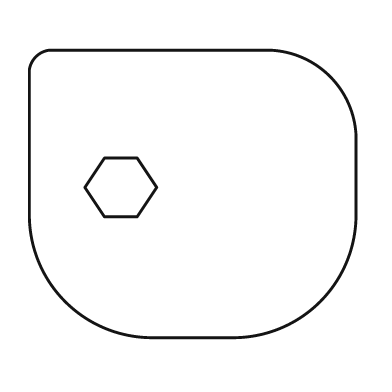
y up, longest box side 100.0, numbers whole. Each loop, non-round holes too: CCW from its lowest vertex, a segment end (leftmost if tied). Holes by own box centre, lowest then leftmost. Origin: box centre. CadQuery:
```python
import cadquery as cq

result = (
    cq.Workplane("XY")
    .moveTo(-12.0, -44.0)
    .lineTo(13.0, -44.0)
    .threePointArc((39.0, -33.0), (50.0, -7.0))
    .lineTo(50.0, 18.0)
    .threePointArc((42.0, 36.0), (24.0, 44.0))
    .lineTo(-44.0, 44.0)
    .threePointArc((-48.0, 42.0), (-50.0, 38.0))
    .lineTo(-50.0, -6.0)
    .threePointArc((-39.0, -33.0), (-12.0, -44.0))
    .close()
    .moveTo(-27.0, -7.0)
    .lineTo(-17.0, -7.0)
    .lineTo(-11.0, 2.0)
    .lineTo(-17.0, 11.0)
    .lineTo(-27.0, 11.0)
    .lineTo(-33.0, 2.0)
    .close()
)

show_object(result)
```